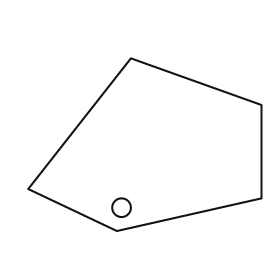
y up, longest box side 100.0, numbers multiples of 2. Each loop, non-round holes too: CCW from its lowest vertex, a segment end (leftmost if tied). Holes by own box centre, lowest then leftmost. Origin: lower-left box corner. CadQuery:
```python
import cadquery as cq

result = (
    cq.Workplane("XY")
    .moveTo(38.0, 0.0)
    .lineTo(100.0, 14.0)
    .lineTo(100.0, 54.0)
    .lineTo(44.0, 74.0)
    .lineTo(0.0, 18.0)
    .close()
    .moveTo(40.0, 10.0)
    .circle(4.0)
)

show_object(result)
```